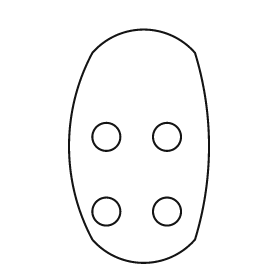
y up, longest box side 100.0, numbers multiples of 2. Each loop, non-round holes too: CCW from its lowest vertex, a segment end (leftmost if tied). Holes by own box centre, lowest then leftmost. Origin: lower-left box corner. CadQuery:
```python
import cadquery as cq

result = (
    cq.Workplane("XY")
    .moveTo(10.0, 10.0)
    .threePointArc((32.0, 0.0), (54.0, 10.0))
    .threePointArc((60.0, 50.0), (54.0, 90.0))
    .threePointArc((32.0, 100.0), (10.0, 90.0))
    .threePointArc((0.0, 50.0), (10.0, 10.0))
    .close()
    .moveTo(16.0, 22.0)
    .circle(6.0)
    .moveTo(42.0, 22.0)
    .circle(6.0)
    .moveTo(16.0, 54.0)
    .circle(6.0)
    .moveTo(42.0, 54.0)
    .circle(6.0)
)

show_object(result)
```